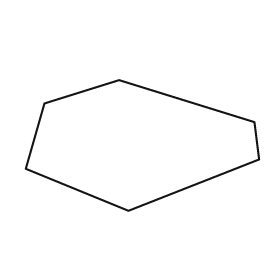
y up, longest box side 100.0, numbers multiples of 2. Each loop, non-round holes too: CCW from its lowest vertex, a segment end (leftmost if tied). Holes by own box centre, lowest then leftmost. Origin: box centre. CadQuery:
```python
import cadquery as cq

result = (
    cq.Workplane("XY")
    .moveTo(-6.0, -28.0)
    .lineTo(50.0, -6.0)
    .lineTo(48.0, 10.0)
    .lineTo(-10.0, 28.0)
    .lineTo(-42.0, 18.0)
    .lineTo(-50.0, -10.0)
    .close()
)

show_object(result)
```